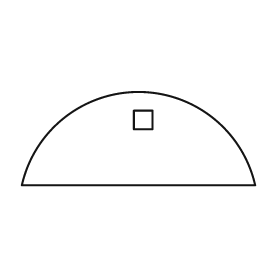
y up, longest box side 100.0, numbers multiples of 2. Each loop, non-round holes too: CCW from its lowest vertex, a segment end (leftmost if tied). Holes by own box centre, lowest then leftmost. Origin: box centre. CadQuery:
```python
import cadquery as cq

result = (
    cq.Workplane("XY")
    .moveTo(-50.0, -20.0)
    .lineTo(50.0, -20.0)
    .threePointArc((0.0, 20.0), (-50.0, -20.0))
    .close()
    .moveTo(-2.0, 4.0)
    .lineTo(6.0, 4.0)
    .lineTo(6.0, 12.0)
    .lineTo(-2.0, 12.0)
    .close()
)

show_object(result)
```